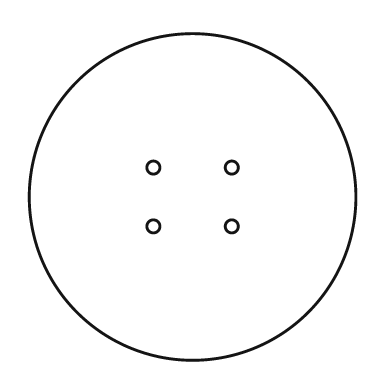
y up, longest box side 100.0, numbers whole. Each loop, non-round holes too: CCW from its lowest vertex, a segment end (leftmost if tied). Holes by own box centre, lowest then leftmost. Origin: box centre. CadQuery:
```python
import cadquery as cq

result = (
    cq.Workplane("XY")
    .moveTo(0.0, 0.0)
    .circle(50.0)
    .moveTo(-12.0, -9.0)
    .circle(2.0)
    .moveTo(12.0, -9.0)
    .circle(2.0)
    .moveTo(-12.0, 9.0)
    .circle(2.0)
    .moveTo(12.0, 9.0)
    .circle(2.0)
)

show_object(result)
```